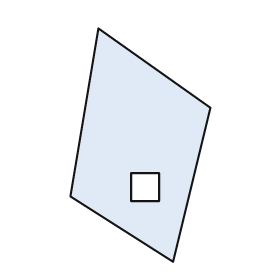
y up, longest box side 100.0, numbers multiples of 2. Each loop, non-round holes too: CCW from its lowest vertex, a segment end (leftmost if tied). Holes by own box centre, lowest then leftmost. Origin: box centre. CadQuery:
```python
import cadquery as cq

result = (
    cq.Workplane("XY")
    .moveTo(14.0, -50.0)
    .lineTo(30.0, 16.0)
    .lineTo(-18.0, 50.0)
    .lineTo(-30.0, -22.0)
    .close()
    .moveTo(-4.0, -24.0)
    .lineTo(8.0, -24.0)
    .lineTo(8.0, -12.0)
    .lineTo(-4.0, -12.0)
    .close()
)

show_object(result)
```